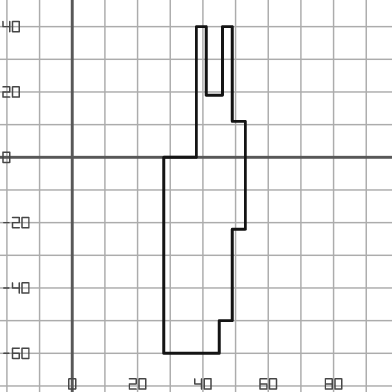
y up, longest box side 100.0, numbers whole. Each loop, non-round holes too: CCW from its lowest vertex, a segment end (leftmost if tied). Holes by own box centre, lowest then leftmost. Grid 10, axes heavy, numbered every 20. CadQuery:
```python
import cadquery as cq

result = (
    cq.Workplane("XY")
    .moveTo(28.0, -60.0)
    .lineTo(45.0, -60.0)
    .lineTo(45.0, -50.0)
    .lineTo(49.0, -50.0)
    .lineTo(49.0, -22.0)
    .lineTo(53.0, -22.0)
    .lineTo(53.0, 11.0)
    .lineTo(49.0, 11.0)
    .lineTo(49.0, 40.0)
    .lineTo(46.0, 40.0)
    .lineTo(46.0, 19.0)
    .lineTo(41.0, 19.0)
    .lineTo(41.0, 40.0)
    .lineTo(38.0, 40.0)
    .lineTo(38.0, 0.0)
    .lineTo(28.0, 0.0)
    .close()
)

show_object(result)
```